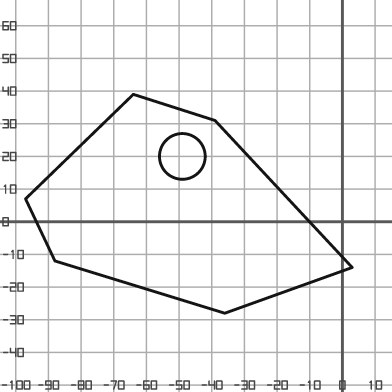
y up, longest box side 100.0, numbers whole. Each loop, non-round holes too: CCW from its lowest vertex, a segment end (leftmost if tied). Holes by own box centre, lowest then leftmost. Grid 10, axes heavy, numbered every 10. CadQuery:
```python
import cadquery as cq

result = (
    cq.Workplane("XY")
    .moveTo(-36.0, -28.0)
    .lineTo(3.0, -14.0)
    .lineTo(-39.0, 31.0)
    .lineTo(-64.0, 39.0)
    .lineTo(-97.0, 7.0)
    .lineTo(-88.0, -12.0)
    .close()
    .moveTo(-49.0, 20.0)
    .circle(7.0)
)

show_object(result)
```